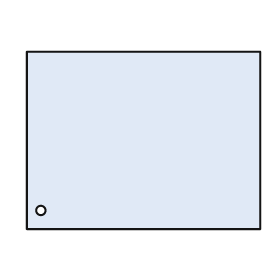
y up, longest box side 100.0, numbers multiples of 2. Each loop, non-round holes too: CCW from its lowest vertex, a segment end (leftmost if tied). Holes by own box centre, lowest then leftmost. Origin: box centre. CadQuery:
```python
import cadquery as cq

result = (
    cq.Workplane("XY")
    .moveTo(-50.0, -38.0)
    .lineTo(50.0, -38.0)
    .lineTo(50.0, 38.0)
    .lineTo(-50.0, 38.0)
    .close()
    .moveTo(-44.0, -30.0)
    .circle(2.0)
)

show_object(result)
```